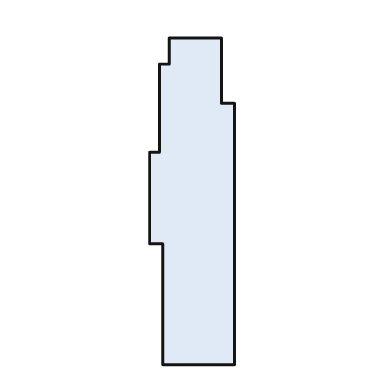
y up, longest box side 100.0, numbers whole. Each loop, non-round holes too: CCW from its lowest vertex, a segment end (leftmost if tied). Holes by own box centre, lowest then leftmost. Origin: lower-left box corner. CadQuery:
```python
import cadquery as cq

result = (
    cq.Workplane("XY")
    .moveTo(4.0, 0.0)
    .lineTo(26.0, 0.0)
    .lineTo(26.0, 80.0)
    .lineTo(22.0, 80.0)
    .lineTo(22.0, 100.0)
    .lineTo(6.0, 100.0)
    .lineTo(6.0, 92.0)
    .lineTo(3.0, 92.0)
    .lineTo(3.0, 65.0)
    .lineTo(0.0, 65.0)
    .lineTo(0.0, 37.0)
    .lineTo(4.0, 37.0)
    .close()
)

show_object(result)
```